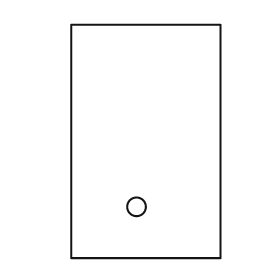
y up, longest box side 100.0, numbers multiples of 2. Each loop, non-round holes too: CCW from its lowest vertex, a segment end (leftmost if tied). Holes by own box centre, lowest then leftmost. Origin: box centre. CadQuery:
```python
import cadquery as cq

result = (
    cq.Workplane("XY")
    .moveTo(-32.0, -50.0)
    .lineTo(32.0, -50.0)
    .lineTo(32.0, 50.0)
    .lineTo(-32.0, 50.0)
    .close()
    .moveTo(-4.0, -28.0)
    .circle(4.0)
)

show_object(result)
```